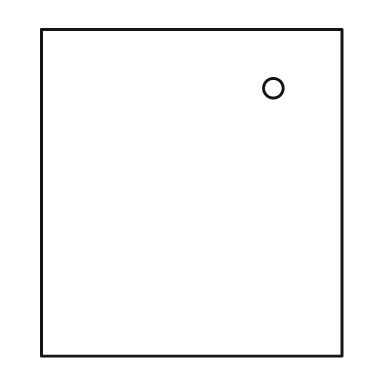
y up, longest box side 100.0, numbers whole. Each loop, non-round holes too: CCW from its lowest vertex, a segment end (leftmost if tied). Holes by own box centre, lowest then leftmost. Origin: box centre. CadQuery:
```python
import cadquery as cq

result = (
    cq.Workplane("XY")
    .moveTo(-46.0, -50.0)
    .lineTo(46.0, -50.0)
    .lineTo(46.0, 50.0)
    .lineTo(-46.0, 50.0)
    .close()
    .moveTo(25.0, 32.0)
    .circle(3.0)
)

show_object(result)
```